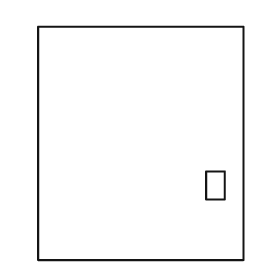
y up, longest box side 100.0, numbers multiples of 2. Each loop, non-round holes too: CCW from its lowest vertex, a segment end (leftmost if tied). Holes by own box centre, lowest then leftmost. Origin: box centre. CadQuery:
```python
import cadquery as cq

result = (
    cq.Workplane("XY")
    .moveTo(-44.0, -50.0)
    .lineTo(44.0, -50.0)
    .lineTo(44.0, 50.0)
    .lineTo(-44.0, 50.0)
    .close()
    .moveTo(28.0, -24.0)
    .lineTo(36.0, -24.0)
    .lineTo(36.0, -12.0)
    .lineTo(28.0, -12.0)
    .close()
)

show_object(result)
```